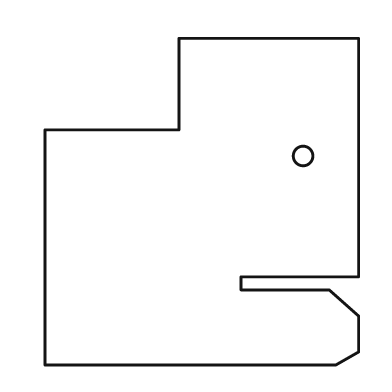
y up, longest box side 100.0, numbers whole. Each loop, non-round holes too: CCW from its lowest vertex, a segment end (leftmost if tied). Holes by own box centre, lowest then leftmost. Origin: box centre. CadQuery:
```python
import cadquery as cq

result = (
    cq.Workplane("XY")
    .moveTo(-48.0, -50.0)
    .lineTo(41.0, -50.0)
    .lineTo(48.0, -46.0)
    .lineTo(48.0, -35.0)
    .lineTo(39.0, -27.0)
    .lineTo(12.0, -27.0)
    .lineTo(12.0, -23.0)
    .lineTo(48.0, -23.0)
    .lineTo(48.0, 50.0)
    .lineTo(-7.0, 50.0)
    .lineTo(-7.0, 22.0)
    .lineTo(-48.0, 22.0)
    .close()
    .moveTo(31.0, 14.0)
    .circle(3.0)
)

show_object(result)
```